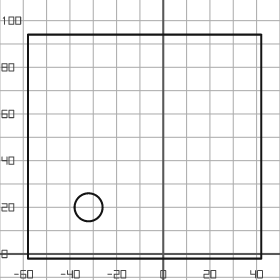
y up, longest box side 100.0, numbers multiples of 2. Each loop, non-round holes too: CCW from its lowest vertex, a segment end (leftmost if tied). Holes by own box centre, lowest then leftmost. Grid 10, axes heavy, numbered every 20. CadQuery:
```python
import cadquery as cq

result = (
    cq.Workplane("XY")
    .moveTo(-58.0, -2.0)
    .lineTo(42.0, -2.0)
    .lineTo(42.0, 94.0)
    .lineTo(-58.0, 94.0)
    .close()
    .moveTo(-32.0, 20.0)
    .circle(6.0)
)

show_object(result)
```